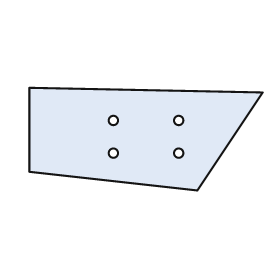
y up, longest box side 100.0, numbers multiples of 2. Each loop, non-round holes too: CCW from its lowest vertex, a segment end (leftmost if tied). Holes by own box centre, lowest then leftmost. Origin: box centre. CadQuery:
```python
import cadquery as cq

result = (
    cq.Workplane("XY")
    .moveTo(22.0, -22.0)
    .lineTo(50.0, 20.0)
    .lineTo(-50.0, 22.0)
    .lineTo(-50.0, -14.0)
    .close()
    .moveTo(-14.0, -6.0)
    .circle(2.0)
    .moveTo(14.0, -6.0)
    .circle(2.0)
    .moveTo(-14.0, 8.0)
    .circle(2.0)
    .moveTo(14.0, 8.0)
    .circle(2.0)
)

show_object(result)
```